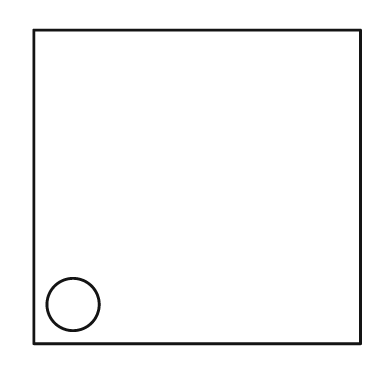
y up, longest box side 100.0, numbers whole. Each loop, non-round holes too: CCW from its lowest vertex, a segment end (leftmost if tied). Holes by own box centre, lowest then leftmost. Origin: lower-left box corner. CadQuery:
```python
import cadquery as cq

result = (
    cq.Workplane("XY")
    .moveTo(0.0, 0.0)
    .lineTo(100.0, 0.0)
    .lineTo(100.0, 96.0)
    .lineTo(0.0, 96.0)
    .close()
    .moveTo(12.0, 12.0)
    .circle(8.0)
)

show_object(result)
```